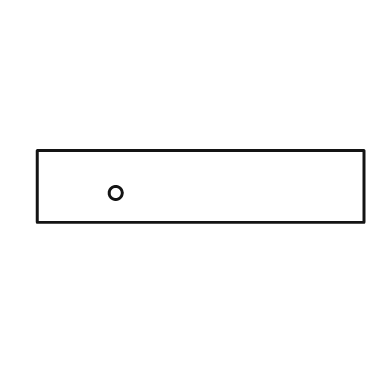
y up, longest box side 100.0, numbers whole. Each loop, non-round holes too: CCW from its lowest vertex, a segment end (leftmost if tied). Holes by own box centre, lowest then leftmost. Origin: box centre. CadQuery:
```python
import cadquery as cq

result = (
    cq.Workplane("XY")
    .moveTo(-50.0, -11.0)
    .lineTo(50.0, -11.0)
    .lineTo(50.0, 11.0)
    .lineTo(-50.0, 11.0)
    .close()
    .moveTo(-26.0, -2.0)
    .circle(2.0)
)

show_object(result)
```